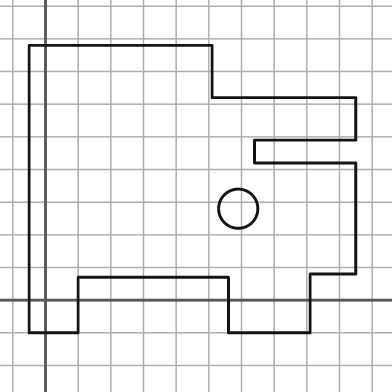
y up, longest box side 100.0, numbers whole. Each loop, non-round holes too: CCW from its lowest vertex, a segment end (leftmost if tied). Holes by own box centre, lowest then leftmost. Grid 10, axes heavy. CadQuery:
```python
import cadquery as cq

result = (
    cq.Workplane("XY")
    .moveTo(-5.0, -10.0)
    .lineTo(10.0, -10.0)
    .lineTo(10.0, 7.0)
    .lineTo(56.0, 7.0)
    .lineTo(56.0, -10.0)
    .lineTo(81.0, -10.0)
    .lineTo(81.0, 8.0)
    .lineTo(95.0, 8.0)
    .lineTo(95.0, 42.0)
    .lineTo(64.0, 42.0)
    .lineTo(64.0, 49.0)
    .lineTo(95.0, 49.0)
    .lineTo(95.0, 62.0)
    .lineTo(51.0, 62.0)
    .lineTo(51.0, 78.0)
    .lineTo(-5.0, 78.0)
    .close()
    .moveTo(59.0, 28.0)
    .circle(6.0)
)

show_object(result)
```